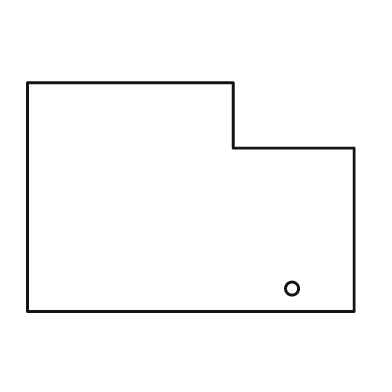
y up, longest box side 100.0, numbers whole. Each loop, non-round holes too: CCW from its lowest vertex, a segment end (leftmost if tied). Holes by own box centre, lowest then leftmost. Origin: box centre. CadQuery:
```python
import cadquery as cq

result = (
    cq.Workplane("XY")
    .moveTo(-50.0, -35.0)
    .lineTo(50.0, -35.0)
    .lineTo(50.0, 15.0)
    .lineTo(13.0, 15.0)
    .lineTo(13.0, 35.0)
    .lineTo(-50.0, 35.0)
    .close()
    .moveTo(31.0, -28.0)
    .circle(2.0)
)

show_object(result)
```